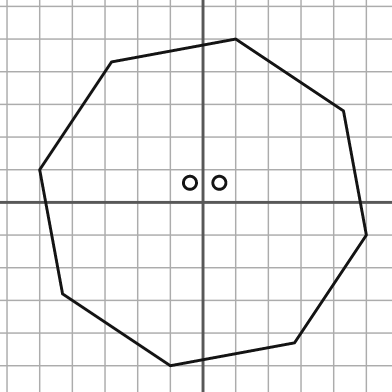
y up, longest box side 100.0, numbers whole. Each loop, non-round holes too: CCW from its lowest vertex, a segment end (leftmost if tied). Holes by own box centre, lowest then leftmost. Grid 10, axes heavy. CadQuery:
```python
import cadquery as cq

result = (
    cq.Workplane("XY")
    .moveTo(-10.0, -50.0)
    .lineTo(28.0, -43.0)
    .lineTo(50.0, -10.0)
    .lineTo(43.0, 28.0)
    .lineTo(10.0, 50.0)
    .lineTo(-28.0, 43.0)
    .lineTo(-50.0, 10.0)
    .lineTo(-43.0, -28.0)
    .close()
    .moveTo(-4.0, 6.0)
    .circle(2.0)
    .moveTo(5.0, 6.0)
    .circle(2.0)
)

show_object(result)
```